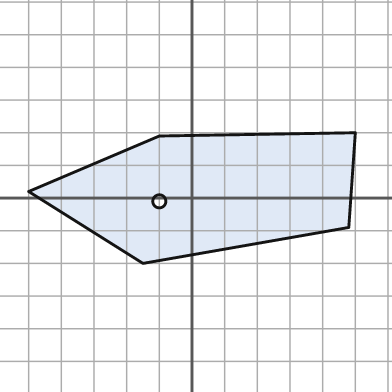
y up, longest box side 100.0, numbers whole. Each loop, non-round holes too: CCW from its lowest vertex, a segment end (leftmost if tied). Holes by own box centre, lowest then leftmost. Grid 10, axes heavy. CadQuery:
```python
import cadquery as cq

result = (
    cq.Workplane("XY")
    .moveTo(-15.0, -20.0)
    .lineTo(48.0, -9.0)
    .lineTo(50.0, 20.0)
    .lineTo(-10.0, 19.0)
    .lineTo(-50.0, 2.0)
    .close()
    .moveTo(-10.0, -1.0)
    .circle(2.0)
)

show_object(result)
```